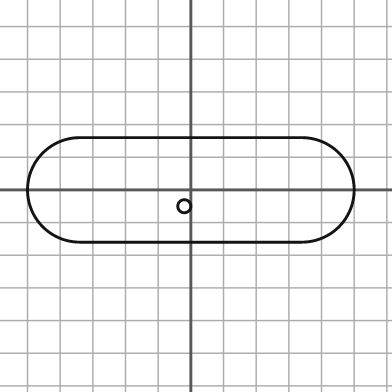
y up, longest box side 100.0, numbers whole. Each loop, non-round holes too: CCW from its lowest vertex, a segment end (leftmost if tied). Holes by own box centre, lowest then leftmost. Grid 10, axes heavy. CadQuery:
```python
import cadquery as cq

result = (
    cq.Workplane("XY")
    .moveTo(-34.0, -16.0)
    .lineTo(34.0, -16.0)
    .threePointArc((50.0, 0.0), (34.0, 16.0))
    .lineTo(-34.0, 16.0)
    .threePointArc((-50.0, 0.0), (-34.0, -16.0))
    .close()
    .moveTo(-2.0, -5.0)
    .circle(2.0)
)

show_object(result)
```